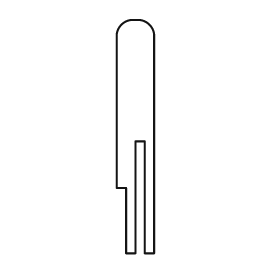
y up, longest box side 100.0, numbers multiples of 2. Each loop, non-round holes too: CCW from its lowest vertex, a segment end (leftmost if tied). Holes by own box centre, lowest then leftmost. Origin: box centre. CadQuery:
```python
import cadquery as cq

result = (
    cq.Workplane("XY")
    .moveTo(-4.0, -50.0)
    .lineTo(0.0, -50.0)
    .lineTo(0.0, -2.0)
    .lineTo(4.0, -2.0)
    .lineTo(4.0, -50.0)
    .lineTo(8.0, -50.0)
    .lineTo(8.0, 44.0)
    .threePointArc((6.0, 48.0), (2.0, 50.0))
    .lineTo(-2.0, 50.0)
    .threePointArc((-6.0, 48.0), (-8.0, 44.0))
    .lineTo(-8.0, -22.0)
    .lineTo(-4.0, -22.0)
    .close()
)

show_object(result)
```